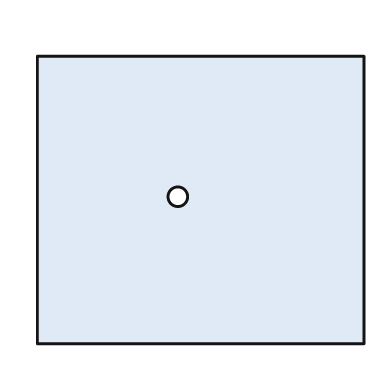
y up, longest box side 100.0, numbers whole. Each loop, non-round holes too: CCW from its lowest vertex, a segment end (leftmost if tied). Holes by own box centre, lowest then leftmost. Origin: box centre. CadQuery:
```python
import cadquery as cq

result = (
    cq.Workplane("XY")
    .moveTo(-50.0, -44.0)
    .lineTo(50.0, -44.0)
    .lineTo(50.0, 44.0)
    .lineTo(-50.0, 44.0)
    .close()
    .moveTo(-7.0, 1.0)
    .circle(3.0)
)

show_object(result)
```